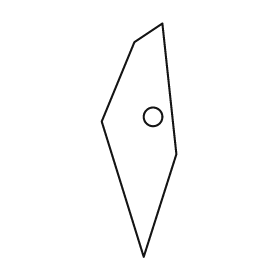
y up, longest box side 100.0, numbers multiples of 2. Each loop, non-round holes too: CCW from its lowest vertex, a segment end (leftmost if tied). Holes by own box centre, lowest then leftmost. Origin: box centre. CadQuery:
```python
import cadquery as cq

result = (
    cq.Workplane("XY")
    .moveTo(2.0, -50.0)
    .lineTo(16.0, -6.0)
    .lineTo(10.0, 50.0)
    .lineTo(-2.0, 42.0)
    .lineTo(-16.0, 8.0)
    .close()
    .moveTo(6.0, 10.0)
    .circle(4.0)
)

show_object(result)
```